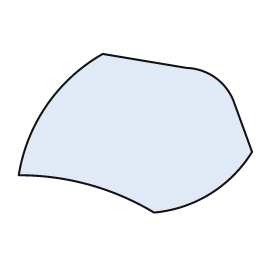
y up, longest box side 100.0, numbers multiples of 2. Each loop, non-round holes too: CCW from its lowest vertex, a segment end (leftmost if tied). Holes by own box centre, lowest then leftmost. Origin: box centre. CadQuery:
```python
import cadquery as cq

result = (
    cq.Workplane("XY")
    .moveTo(8.0, -34.0)
    .threePointArc((32.0, -26.0), (50.0, -8.0))
    .lineTo(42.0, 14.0)
    .threePointArc((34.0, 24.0), (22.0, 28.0))
    .lineTo(-14.0, 34.0)
    .threePointArc((-38.0, 12.0), (-50.0, -18.0))
    .threePointArc((-20.0, -22.0), (8.0, -34.0))
    .close()
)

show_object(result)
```